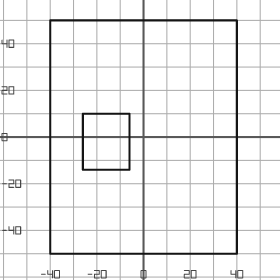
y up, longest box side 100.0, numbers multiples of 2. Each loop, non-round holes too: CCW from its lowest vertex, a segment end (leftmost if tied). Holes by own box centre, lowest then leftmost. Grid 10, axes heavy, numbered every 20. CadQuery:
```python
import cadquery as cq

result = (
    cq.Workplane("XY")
    .moveTo(-40.0, -50.0)
    .lineTo(40.0, -50.0)
    .lineTo(40.0, 50.0)
    .lineTo(-40.0, 50.0)
    .close()
    .moveTo(-26.0, -14.0)
    .lineTo(-6.0, -14.0)
    .lineTo(-6.0, 10.0)
    .lineTo(-26.0, 10.0)
    .close()
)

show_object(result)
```